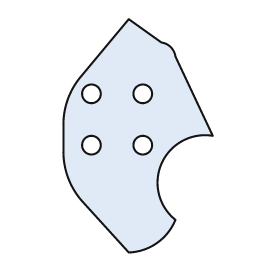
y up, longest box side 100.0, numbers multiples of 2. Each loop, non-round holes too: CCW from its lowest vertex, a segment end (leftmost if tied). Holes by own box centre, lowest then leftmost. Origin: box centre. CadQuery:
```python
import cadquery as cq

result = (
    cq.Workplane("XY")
    .moveTo(-4.0, -50.0)
    .threePointArc((8.0, -46.0), (16.0, -36.0))
    .threePointArc((10.0, -12.0), (32.0, 0.0))
    .lineTo(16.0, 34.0)
    .threePointArc((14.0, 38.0), (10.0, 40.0))
    .lineTo(-4.0, 50.0)
    .lineTo(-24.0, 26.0)
    .threePointArc((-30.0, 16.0), (-32.0, 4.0))
    .lineTo(-32.0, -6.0)
    .threePointArc((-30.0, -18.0), (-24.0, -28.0))
    .close()
    .moveTo(-20.0, -4.0)
    .circle(4.0)
    .moveTo(2.0, -4.0)
    .circle(4.0)
    .moveTo(-20.0, 18.0)
    .circle(4.0)
    .moveTo(2.0, 18.0)
    .circle(4.0)
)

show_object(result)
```